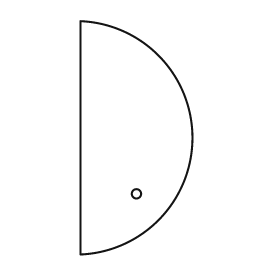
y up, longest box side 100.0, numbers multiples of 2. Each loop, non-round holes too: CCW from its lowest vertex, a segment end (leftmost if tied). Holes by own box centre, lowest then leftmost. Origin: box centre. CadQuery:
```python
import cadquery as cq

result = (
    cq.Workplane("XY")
    .moveTo(-24.0, -50.0)
    .threePointArc((24.0, 0.0), (-24.0, 50.0))
    .close()
    .moveTo(0.0, -24.0)
    .circle(2.0)
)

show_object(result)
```